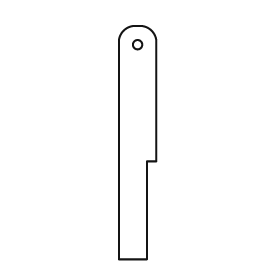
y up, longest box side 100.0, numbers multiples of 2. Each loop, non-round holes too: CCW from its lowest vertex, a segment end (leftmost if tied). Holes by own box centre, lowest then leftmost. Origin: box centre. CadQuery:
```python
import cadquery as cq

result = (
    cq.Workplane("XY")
    .moveTo(-8.0, -50.0)
    .lineTo(4.0, -50.0)
    .lineTo(4.0, -8.0)
    .lineTo(8.0, -8.0)
    .lineTo(8.0, 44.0)
    .threePointArc((6.0, 48.0), (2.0, 50.0))
    .lineTo(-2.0, 50.0)
    .threePointArc((-6.0, 48.0), (-8.0, 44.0))
    .close()
    .moveTo(0.0, 42.0)
    .circle(2.0)
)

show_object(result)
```